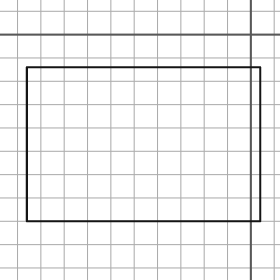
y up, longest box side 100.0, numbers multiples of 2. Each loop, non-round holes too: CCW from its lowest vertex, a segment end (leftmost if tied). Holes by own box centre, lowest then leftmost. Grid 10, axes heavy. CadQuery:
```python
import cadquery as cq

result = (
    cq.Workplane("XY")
    .moveTo(-96.0, -80.0)
    .lineTo(4.0, -80.0)
    .lineTo(4.0, -14.0)
    .lineTo(-96.0, -14.0)
    .close()
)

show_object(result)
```